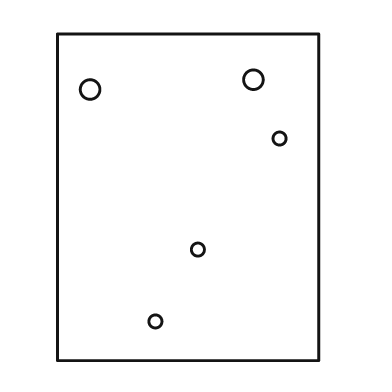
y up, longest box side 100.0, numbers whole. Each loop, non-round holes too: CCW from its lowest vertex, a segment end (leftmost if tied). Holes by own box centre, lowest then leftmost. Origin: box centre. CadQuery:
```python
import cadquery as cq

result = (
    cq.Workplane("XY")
    .moveTo(-40.0, -50.0)
    .lineTo(40.0, -50.0)
    .lineTo(40.0, 50.0)
    .lineTo(-40.0, 50.0)
    .close()
    .moveTo(-10.0, -38.0)
    .circle(2.0)
    .moveTo(3.0, -16.0)
    .circle(2.0)
    .moveTo(28.0, 18.0)
    .circle(2.0)
    .moveTo(-30.0, 33.0)
    .circle(3.0)
    .moveTo(20.0, 36.0)
    .circle(3.0)
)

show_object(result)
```